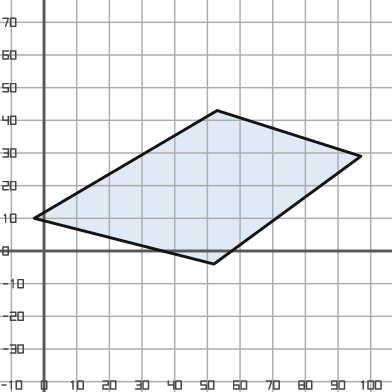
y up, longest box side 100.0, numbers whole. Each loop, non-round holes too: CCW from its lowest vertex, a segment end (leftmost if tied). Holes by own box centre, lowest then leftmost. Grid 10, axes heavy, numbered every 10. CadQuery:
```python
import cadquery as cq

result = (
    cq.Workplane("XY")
    .moveTo(52.0, -4.0)
    .lineTo(97.0, 29.0)
    .lineTo(53.0, 43.0)
    .lineTo(-3.0, 10.0)
    .close()
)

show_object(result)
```